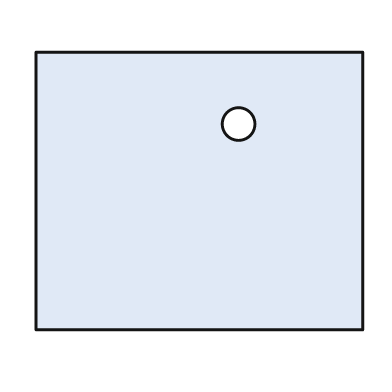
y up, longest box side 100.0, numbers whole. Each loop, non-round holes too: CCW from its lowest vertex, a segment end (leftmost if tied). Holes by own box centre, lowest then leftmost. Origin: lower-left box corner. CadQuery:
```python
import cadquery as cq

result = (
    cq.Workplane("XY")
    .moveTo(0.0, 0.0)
    .lineTo(100.0, 0.0)
    .lineTo(100.0, 85.0)
    .lineTo(0.0, 85.0)
    .close()
    .moveTo(62.0, 63.0)
    .circle(5.0)
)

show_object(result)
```